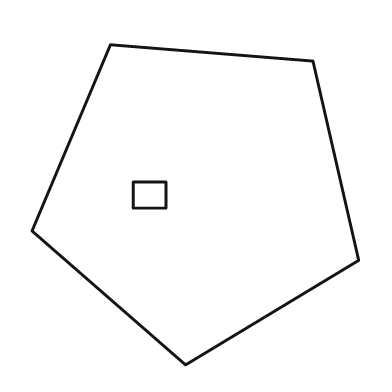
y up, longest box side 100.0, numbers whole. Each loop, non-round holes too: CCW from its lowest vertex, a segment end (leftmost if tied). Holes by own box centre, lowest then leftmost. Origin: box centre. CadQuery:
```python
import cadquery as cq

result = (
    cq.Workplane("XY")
    .moveTo(-3.0, -49.0)
    .lineTo(50.0, -17.0)
    .lineTo(36.0, 44.0)
    .lineTo(-26.0, 49.0)
    .lineTo(-50.0, -8.0)
    .close()
    .moveTo(-19.0, -1.0)
    .lineTo(-9.0, -1.0)
    .lineTo(-9.0, 7.0)
    .lineTo(-19.0, 7.0)
    .close()
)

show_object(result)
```